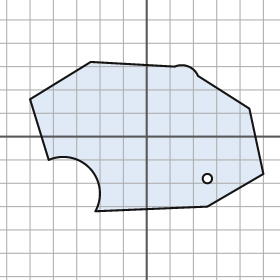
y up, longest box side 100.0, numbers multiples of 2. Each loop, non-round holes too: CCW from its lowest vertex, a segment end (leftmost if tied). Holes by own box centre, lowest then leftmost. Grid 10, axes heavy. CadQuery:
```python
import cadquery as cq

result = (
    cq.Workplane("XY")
    .moveTo(-22.0, -32.0)
    .lineTo(26.0, -30.0)
    .lineTo(50.0, -16.0)
    .lineTo(44.0, 12.0)
    .lineTo(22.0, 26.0)
    .threePointArc((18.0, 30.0), (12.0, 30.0))
    .lineTo(-24.0, 32.0)
    .lineTo(-50.0, 16.0)
    .lineTo(-42.0, -10.0)
    .threePointArc((-24.0, -14.0), (-22.0, -32.0))
    .close()
    .moveTo(26.0, -18.0)
    .circle(2.0)
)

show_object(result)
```